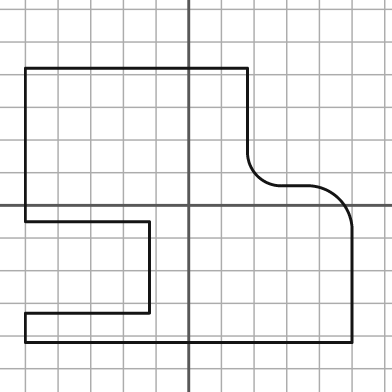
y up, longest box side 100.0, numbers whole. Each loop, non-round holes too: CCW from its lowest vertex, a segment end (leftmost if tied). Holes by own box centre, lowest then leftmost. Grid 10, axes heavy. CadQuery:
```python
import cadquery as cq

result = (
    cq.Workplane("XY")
    .moveTo(-50.0, -42.0)
    .lineTo(50.0, -42.0)
    .lineTo(50.0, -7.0)
    .threePointArc((46.0, 2.0), (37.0, 6.0))
    .lineTo(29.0, 6.0)
    .threePointArc((21.0, 9.0), (18.0, 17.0))
    .lineTo(18.0, 42.0)
    .lineTo(-50.0, 42.0)
    .lineTo(-50.0, -5.0)
    .lineTo(-12.0, -5.0)
    .lineTo(-12.0, -33.0)
    .lineTo(-50.0, -33.0)
    .close()
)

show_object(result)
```